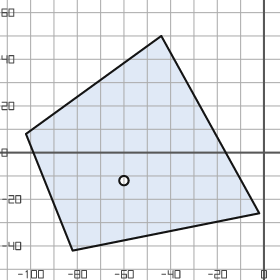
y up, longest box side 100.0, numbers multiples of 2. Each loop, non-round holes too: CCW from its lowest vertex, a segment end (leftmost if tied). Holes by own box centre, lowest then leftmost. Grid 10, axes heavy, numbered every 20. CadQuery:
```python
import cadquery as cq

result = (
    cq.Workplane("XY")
    .moveTo(-82.0, -42.0)
    .lineTo(-2.0, -26.0)
    .lineTo(-44.0, 50.0)
    .lineTo(-102.0, 8.0)
    .close()
    .moveTo(-60.0, -12.0)
    .circle(2.0)
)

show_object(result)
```